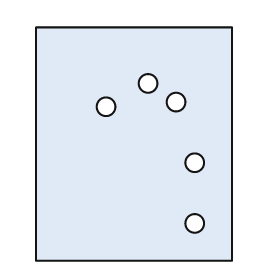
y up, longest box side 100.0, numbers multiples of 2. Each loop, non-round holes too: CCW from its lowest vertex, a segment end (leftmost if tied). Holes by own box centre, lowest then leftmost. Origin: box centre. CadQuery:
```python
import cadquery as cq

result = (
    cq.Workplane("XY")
    .moveTo(-42.0, -50.0)
    .lineTo(42.0, -50.0)
    .lineTo(42.0, 50.0)
    .lineTo(-42.0, 50.0)
    .close()
    .moveTo(26.0, -34.0)
    .circle(4.0)
    .moveTo(26.0, -8.0)
    .circle(4.0)
    .moveTo(-12.0, 16.0)
    .circle(4.0)
    .moveTo(18.0, 18.0)
    .circle(4.0)
    .moveTo(6.0, 26.0)
    .circle(4.0)
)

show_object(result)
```